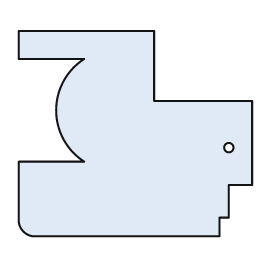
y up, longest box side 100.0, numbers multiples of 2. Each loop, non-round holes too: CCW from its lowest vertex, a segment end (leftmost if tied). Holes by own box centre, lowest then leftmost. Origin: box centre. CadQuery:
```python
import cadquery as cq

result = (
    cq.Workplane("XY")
    .moveTo(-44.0, -44.0)
    .lineTo(36.0, -44.0)
    .lineTo(36.0, -36.0)
    .lineTo(40.0, -36.0)
    .lineTo(40.0, -22.0)
    .lineTo(50.0, -22.0)
    .lineTo(50.0, 14.0)
    .lineTo(8.0, 14.0)
    .lineTo(8.0, 44.0)
    .lineTo(-50.0, 44.0)
    .lineTo(-50.0, 32.0)
    .lineTo(-22.0, 32.0)
    .threePointArc((-34.0, 10.0), (-22.0, -12.0))
    .lineTo(-50.0, -12.0)
    .lineTo(-50.0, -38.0)
    .threePointArc((-48.0, -42.0), (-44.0, -44.0))
    .close()
    .moveTo(40.0, -6.0)
    .circle(2.0)
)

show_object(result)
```